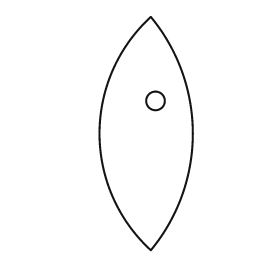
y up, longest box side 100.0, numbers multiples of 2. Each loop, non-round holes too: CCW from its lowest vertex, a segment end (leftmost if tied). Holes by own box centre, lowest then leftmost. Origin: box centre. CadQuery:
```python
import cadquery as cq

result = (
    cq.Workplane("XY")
    .moveTo(2.0, -50.0)
    .threePointArc((20.0, 0.0), (2.0, 50.0))
    .threePointArc((-20.0, 0.0), (2.0, -50.0))
    .close()
    .moveTo(4.0, 14.0)
    .circle(4.0)
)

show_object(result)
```